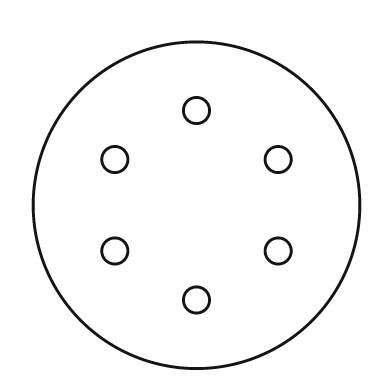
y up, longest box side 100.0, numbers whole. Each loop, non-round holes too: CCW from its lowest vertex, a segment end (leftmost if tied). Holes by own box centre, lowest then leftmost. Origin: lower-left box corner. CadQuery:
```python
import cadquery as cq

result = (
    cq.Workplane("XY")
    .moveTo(50.0, 50.0)
    .circle(50.0)
    .moveTo(50.0, 21.0)
    .circle(4.0)
    .moveTo(25.0, 36.0)
    .circle(4.0)
    .moveTo(75.0, 36.0)
    .circle(4.0)
    .moveTo(25.0, 64.0)
    .circle(4.0)
    .moveTo(75.0, 64.0)
    .circle(4.0)
    .moveTo(50.0, 79.0)
    .circle(4.0)
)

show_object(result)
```